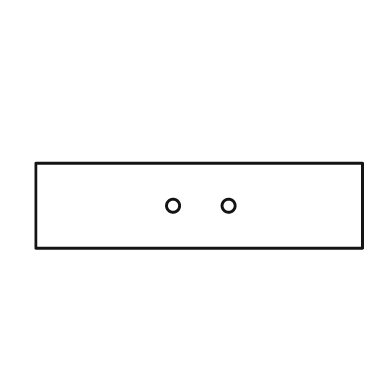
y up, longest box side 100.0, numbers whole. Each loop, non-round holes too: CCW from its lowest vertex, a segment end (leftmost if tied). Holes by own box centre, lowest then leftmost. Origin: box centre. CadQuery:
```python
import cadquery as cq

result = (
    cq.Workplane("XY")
    .moveTo(-50.0, -13.0)
    .lineTo(50.0, -13.0)
    .lineTo(50.0, 13.0)
    .lineTo(-50.0, 13.0)
    .close()
    .moveTo(-8.0, 0.0)
    .circle(2.0)
    .moveTo(9.0, 0.0)
    .circle(2.0)
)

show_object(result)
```